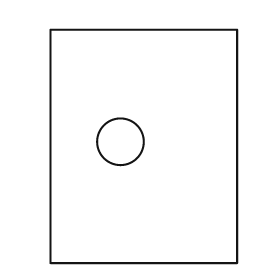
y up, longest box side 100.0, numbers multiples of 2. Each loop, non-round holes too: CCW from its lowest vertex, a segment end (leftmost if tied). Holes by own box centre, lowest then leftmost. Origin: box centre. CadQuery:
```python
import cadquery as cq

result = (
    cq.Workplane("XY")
    .moveTo(-40.0, -50.0)
    .lineTo(40.0, -50.0)
    .lineTo(40.0, 50.0)
    .lineTo(-40.0, 50.0)
    .close()
    .moveTo(-10.0, 2.0)
    .circle(10.0)
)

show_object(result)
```